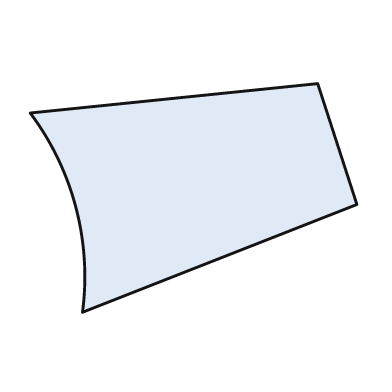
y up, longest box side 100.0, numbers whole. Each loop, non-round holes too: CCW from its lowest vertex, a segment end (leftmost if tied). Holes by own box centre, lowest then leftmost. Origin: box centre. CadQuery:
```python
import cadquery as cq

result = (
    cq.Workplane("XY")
    .moveTo(-34.0, -35.0)
    .lineTo(50.0, -2.0)
    .lineTo(38.0, 35.0)
    .lineTo(-50.0, 26.0)
    .threePointArc((-36.0, -3.0), (-34.0, -35.0))
    .close()
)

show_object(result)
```